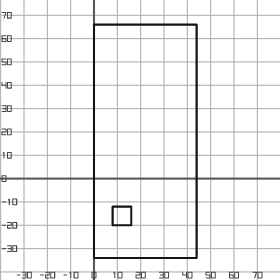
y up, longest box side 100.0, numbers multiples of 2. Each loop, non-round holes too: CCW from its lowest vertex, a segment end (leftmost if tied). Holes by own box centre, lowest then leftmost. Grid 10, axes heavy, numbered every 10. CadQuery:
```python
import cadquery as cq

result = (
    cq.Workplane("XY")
    .moveTo(0.0, -34.0)
    .lineTo(44.0, -34.0)
    .lineTo(44.0, 66.0)
    .lineTo(0.0, 66.0)
    .close()
    .moveTo(8.0, -20.0)
    .lineTo(16.0, -20.0)
    .lineTo(16.0, -12.0)
    .lineTo(8.0, -12.0)
    .close()
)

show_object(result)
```